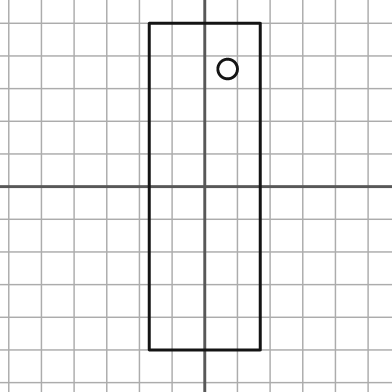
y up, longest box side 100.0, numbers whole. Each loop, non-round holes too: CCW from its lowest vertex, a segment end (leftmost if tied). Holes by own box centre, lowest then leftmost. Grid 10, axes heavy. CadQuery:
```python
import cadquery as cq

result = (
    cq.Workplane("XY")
    .moveTo(-17.0, -50.0)
    .lineTo(17.0, -50.0)
    .lineTo(17.0, 50.0)
    .lineTo(-17.0, 50.0)
    .close()
    .moveTo(7.0, 36.0)
    .circle(3.0)
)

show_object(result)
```